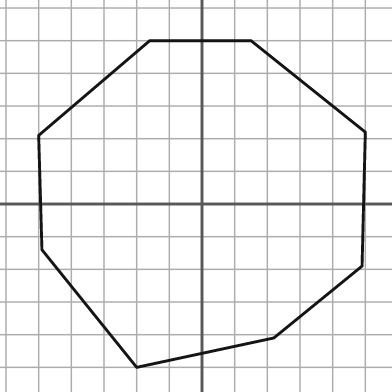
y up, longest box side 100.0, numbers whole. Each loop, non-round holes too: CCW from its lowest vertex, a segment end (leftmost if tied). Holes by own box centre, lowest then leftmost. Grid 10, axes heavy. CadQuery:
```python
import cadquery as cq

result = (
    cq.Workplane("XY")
    .moveTo(-20.0, -50.0)
    .lineTo(22.0, -41.0)
    .lineTo(49.0, -19.0)
    .lineTo(50.0, 22.0)
    .lineTo(15.0, 50.0)
    .lineTo(-16.0, 50.0)
    .lineTo(-50.0, 21.0)
    .lineTo(-49.0, -14.0)
    .close()
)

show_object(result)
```